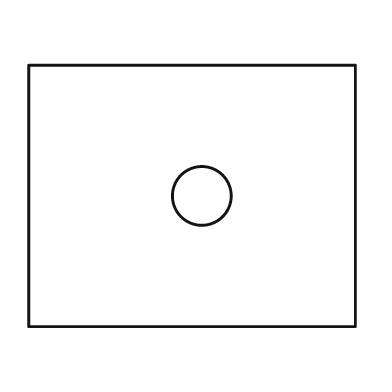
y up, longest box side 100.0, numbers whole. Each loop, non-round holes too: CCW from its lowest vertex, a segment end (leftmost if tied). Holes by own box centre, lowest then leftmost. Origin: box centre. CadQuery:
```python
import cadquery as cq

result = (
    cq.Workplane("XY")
    .moveTo(-50.0, -40.0)
    .lineTo(50.0, -40.0)
    .lineTo(50.0, 40.0)
    .lineTo(-50.0, 40.0)
    .close()
    .moveTo(3.0, 0.0)
    .circle(9.0)
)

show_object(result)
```